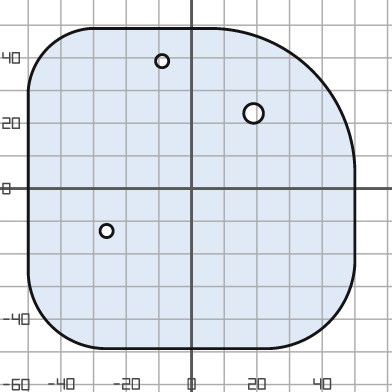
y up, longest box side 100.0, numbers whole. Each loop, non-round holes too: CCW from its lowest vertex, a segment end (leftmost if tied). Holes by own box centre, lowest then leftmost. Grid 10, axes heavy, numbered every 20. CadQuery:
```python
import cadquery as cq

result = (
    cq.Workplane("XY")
    .moveTo(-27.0, -49.0)
    .lineTo(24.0, -49.0)
    .threePointArc((42.0, -41.0), (50.0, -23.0))
    .lineTo(50.0, 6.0)
    .threePointArc((37.0, 36.0), (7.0, 49.0))
    .lineTo(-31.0, 49.0)
    .threePointArc((-44.0, 43.0), (-50.0, 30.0))
    .lineTo(-50.0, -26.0)
    .threePointArc((-43.0, -42.0), (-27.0, -49.0))
    .close()
    .moveTo(-26.0, -13.0)
    .circle(2.0)
    .moveTo(19.0, 23.0)
    .circle(3.0)
    .moveTo(-9.0, 39.0)
    .circle(2.0)
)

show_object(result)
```